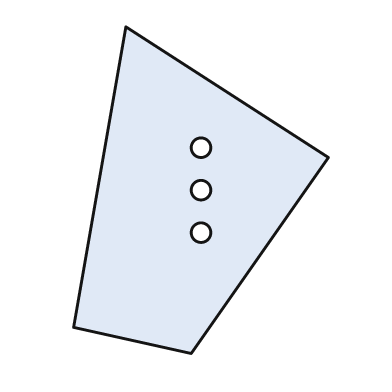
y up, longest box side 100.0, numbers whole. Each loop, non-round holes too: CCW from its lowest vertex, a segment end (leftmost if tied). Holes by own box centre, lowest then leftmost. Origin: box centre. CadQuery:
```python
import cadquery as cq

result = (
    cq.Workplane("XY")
    .moveTo(-3.0, -50.0)
    .lineTo(39.0, 10.0)
    .lineTo(-23.0, 50.0)
    .lineTo(-39.0, -42.0)
    .close()
    .moveTo(0.0, -13.0)
    .circle(3.0)
    .moveTo(0.0, 0.0)
    .circle(3.0)
    .moveTo(0.0, 13.0)
    .circle(3.0)
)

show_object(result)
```